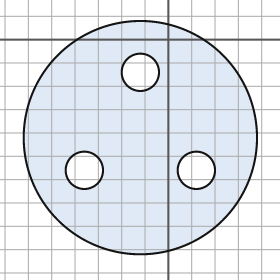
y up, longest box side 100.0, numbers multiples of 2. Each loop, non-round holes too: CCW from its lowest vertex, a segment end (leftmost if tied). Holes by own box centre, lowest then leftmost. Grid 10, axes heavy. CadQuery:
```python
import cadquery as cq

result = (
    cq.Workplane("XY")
    .moveTo(-12.0, -42.0)
    .circle(50.0)
    .moveTo(-36.0, -56.0)
    .circle(8.0)
    .moveTo(12.0, -56.0)
    .circle(8.0)
    .moveTo(-12.0, -14.0)
    .circle(8.0)
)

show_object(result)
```